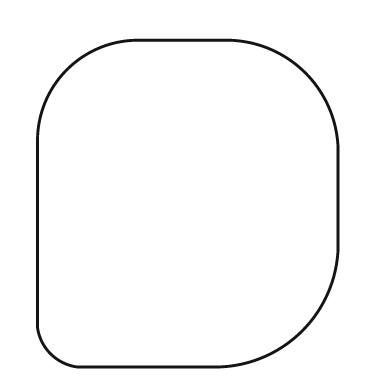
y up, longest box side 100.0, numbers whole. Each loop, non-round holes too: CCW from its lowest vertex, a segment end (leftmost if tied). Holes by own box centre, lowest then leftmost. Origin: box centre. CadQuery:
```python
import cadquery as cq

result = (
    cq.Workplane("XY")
    .moveTo(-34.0, -50.0)
    .lineTo(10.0, -50.0)
    .threePointArc((35.0, -39.0), (46.0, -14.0))
    .lineTo(46.0, 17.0)
    .threePointArc((36.0, 40.0), (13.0, 50.0))
    .lineTo(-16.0, 50.0)
    .threePointArc((-37.0, 41.0), (-46.0, 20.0))
    .lineTo(-46.0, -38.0)
    .threePointArc((-42.0, -46.0), (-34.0, -50.0))
    .close()
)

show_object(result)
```